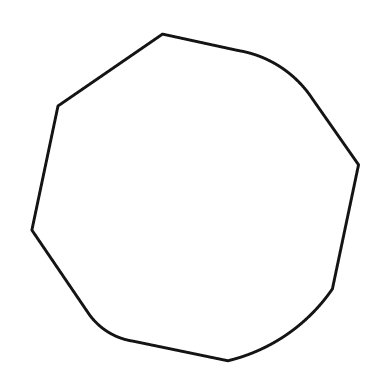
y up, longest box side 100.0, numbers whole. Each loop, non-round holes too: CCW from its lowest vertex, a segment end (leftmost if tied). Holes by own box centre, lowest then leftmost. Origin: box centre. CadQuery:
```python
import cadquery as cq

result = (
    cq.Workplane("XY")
    .moveTo(10.0, -50.0)
    .threePointArc((28.0, -42.0), (42.0, -28.0))
    .lineTo(50.0, 10.0)
    .lineTo(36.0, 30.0)
    .threePointArc((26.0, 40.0), (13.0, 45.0))
    .lineTo(-10.0, 50.0)
    .lineTo(-42.0, 28.0)
    .lineTo(-50.0, -10.0)
    .lineTo(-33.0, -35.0)
    .threePointArc((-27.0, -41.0), (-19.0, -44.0))
    .close()
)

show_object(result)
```